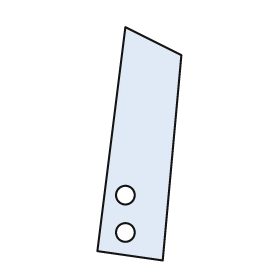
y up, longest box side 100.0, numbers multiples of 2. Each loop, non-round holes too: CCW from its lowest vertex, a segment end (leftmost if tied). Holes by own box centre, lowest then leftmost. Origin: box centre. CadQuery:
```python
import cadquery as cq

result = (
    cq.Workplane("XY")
    .moveTo(10.0, -50.0)
    .lineTo(18.0, 38.0)
    .lineTo(-6.0, 50.0)
    .lineTo(-18.0, -46.0)
    .close()
    .moveTo(-6.0, -38.0)
    .circle(4.0)
    .moveTo(-6.0, -22.0)
    .circle(4.0)
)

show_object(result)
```